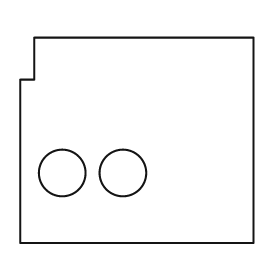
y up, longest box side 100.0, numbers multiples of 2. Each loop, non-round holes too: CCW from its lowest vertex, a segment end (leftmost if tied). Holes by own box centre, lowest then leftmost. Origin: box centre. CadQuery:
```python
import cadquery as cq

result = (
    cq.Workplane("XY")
    .moveTo(-50.0, -44.0)
    .lineTo(50.0, -44.0)
    .lineTo(50.0, 44.0)
    .lineTo(-44.0, 44.0)
    .lineTo(-44.0, 26.0)
    .lineTo(-50.0, 26.0)
    .close()
    .moveTo(-32.0, -14.0)
    .circle(10.0)
    .moveTo(-6.0, -14.0)
    .circle(10.0)
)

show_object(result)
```